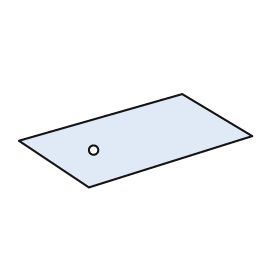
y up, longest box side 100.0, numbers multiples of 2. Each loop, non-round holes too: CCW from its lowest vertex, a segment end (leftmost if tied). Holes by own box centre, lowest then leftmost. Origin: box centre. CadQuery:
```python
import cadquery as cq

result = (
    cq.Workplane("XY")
    .moveTo(-20.0, -20.0)
    .lineTo(50.0, 2.0)
    .lineTo(20.0, 20.0)
    .lineTo(-50.0, 0.0)
    .close()
    .moveTo(-18.0, -4.0)
    .circle(2.0)
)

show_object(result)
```